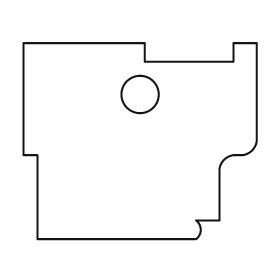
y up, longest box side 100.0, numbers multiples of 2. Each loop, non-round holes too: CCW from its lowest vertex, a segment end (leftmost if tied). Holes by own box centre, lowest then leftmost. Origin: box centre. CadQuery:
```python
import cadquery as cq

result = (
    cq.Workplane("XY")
    .moveTo(-44.0, -42.0)
    .lineTo(24.0, -42.0)
    .threePointArc((26.0, -38.0), (24.0, -34.0))
    .lineTo(34.0, -34.0)
    .lineTo(34.0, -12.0)
    .threePointArc((36.0, -8.0), (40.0, -6.0))
    .lineTo(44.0, -6.0)
    .threePointArc((48.0, -4.0), (50.0, 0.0))
    .lineTo(50.0, 42.0)
    .lineTo(40.0, 42.0)
    .lineTo(40.0, 34.0)
    .lineTo(2.0, 34.0)
    .lineTo(2.0, 42.0)
    .lineTo(-50.0, 42.0)
    .lineTo(-50.0, -6.0)
    .lineTo(-44.0, -6.0)
    .close()
    .moveTo(0.0, 20.0)
    .circle(8.0)
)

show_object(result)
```